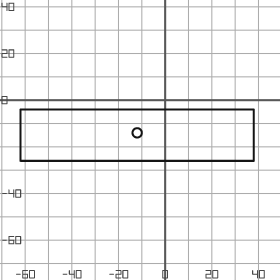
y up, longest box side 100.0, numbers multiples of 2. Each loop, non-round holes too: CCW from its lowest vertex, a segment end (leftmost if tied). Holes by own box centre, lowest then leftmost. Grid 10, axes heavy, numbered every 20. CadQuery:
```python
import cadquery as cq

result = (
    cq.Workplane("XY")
    .moveTo(-62.0, -26.0)
    .lineTo(38.0, -26.0)
    .lineTo(38.0, -4.0)
    .lineTo(-62.0, -4.0)
    .close()
    .moveTo(-12.0, -14.0)
    .circle(2.0)
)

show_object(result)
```